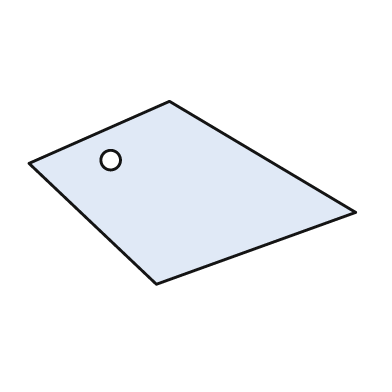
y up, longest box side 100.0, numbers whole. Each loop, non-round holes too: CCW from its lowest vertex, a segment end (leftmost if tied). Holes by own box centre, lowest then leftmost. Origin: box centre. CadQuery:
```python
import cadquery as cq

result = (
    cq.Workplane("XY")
    .moveTo(-11.0, -28.0)
    .lineTo(50.0, -6.0)
    .lineTo(-7.0, 28.0)
    .lineTo(-50.0, 9.0)
    .close()
    .moveTo(-25.0, 10.0)
    .circle(3.0)
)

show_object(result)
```